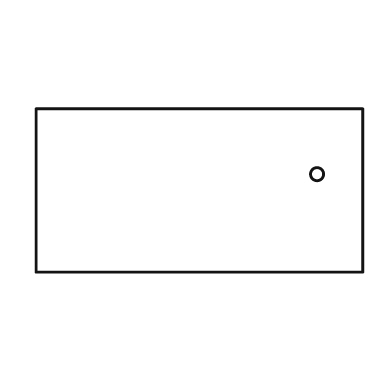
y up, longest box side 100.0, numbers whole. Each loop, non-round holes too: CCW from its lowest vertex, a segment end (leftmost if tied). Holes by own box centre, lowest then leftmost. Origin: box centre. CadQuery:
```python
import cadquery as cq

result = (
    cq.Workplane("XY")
    .moveTo(-50.0, -25.0)
    .lineTo(50.0, -25.0)
    .lineTo(50.0, 25.0)
    .lineTo(-50.0, 25.0)
    .close()
    .moveTo(36.0, 5.0)
    .circle(2.0)
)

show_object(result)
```